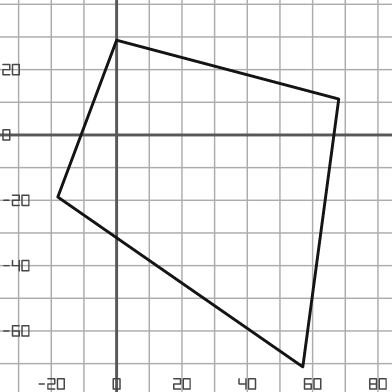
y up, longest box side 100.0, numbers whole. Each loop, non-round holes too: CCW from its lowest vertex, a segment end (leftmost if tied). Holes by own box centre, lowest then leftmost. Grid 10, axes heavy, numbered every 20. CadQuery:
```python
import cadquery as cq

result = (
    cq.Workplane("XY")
    .moveTo(57.0, -71.0)
    .lineTo(68.0, 11.0)
    .lineTo(0.0, 29.0)
    .lineTo(-18.0, -19.0)
    .close()
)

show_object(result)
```